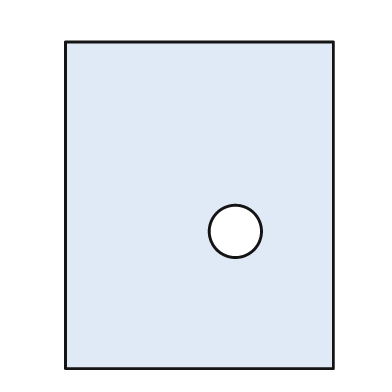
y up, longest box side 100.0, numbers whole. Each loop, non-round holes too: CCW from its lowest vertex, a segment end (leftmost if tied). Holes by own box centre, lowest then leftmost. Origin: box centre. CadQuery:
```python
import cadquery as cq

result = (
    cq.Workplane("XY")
    .moveTo(-41.0, -50.0)
    .lineTo(41.0, -50.0)
    .lineTo(41.0, 50.0)
    .lineTo(-41.0, 50.0)
    .close()
    .moveTo(11.0, -8.0)
    .circle(8.0)
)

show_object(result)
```